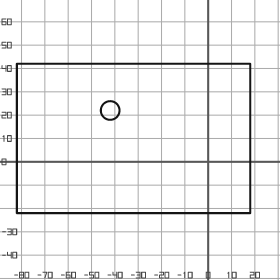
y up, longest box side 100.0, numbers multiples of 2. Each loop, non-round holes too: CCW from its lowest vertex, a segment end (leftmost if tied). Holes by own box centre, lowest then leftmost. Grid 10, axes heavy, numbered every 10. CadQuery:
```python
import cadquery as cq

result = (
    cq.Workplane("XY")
    .moveTo(-82.0, -22.0)
    .lineTo(18.0, -22.0)
    .lineTo(18.0, 42.0)
    .lineTo(-82.0, 42.0)
    .close()
    .moveTo(-42.0, 22.0)
    .circle(4.0)
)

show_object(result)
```